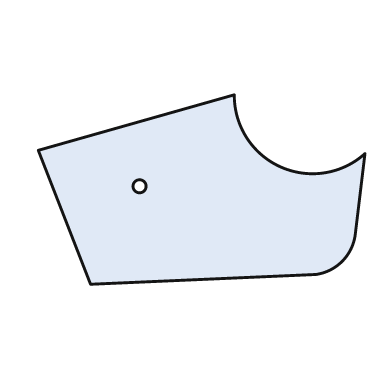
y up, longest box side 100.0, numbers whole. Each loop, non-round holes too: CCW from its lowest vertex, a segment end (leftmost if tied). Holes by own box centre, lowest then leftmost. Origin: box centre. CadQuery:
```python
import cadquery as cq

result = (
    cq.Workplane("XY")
    .moveTo(-34.0, -29.0)
    .lineTo(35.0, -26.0)
    .threePointArc((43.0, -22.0), (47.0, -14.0))
    .lineTo(50.0, 11.0)
    .threePointArc((24.0, 7.0), (10.0, 29.0))
    .lineTo(-50.0, 12.0)
    .close()
    .moveTo(-19.0, 1.0)
    .circle(2.0)
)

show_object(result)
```